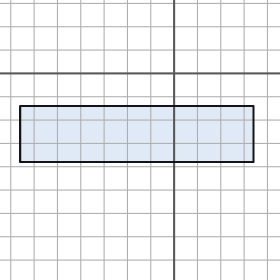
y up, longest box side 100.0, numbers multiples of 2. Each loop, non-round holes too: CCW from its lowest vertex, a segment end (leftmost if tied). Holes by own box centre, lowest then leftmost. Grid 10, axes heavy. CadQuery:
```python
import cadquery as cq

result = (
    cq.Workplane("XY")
    .moveTo(-66.0, -38.0)
    .lineTo(34.0, -38.0)
    .lineTo(34.0, -14.0)
    .lineTo(-66.0, -14.0)
    .close()
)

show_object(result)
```